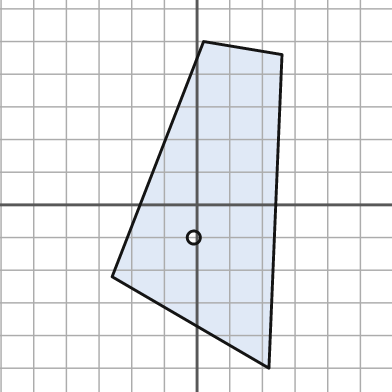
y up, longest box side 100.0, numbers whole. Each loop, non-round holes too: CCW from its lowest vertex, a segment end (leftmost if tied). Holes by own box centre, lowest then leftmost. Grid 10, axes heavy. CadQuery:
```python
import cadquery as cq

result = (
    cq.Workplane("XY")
    .moveTo(22.0, -50.0)
    .lineTo(26.0, 46.0)
    .lineTo(2.0, 50.0)
    .lineTo(-26.0, -22.0)
    .close()
    .moveTo(-1.0, -10.0)
    .circle(2.0)
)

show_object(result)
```